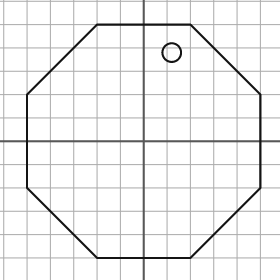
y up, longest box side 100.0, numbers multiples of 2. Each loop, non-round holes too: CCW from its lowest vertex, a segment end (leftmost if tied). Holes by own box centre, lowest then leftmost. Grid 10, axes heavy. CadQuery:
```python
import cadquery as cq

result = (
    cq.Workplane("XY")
    .moveTo(-20.0, -50.0)
    .lineTo(20.0, -50.0)
    .lineTo(50.0, -20.0)
    .lineTo(50.0, 20.0)
    .lineTo(20.0, 50.0)
    .lineTo(-20.0, 50.0)
    .lineTo(-50.0, 20.0)
    .lineTo(-50.0, -20.0)
    .close()
    .moveTo(12.0, 38.0)
    .circle(4.0)
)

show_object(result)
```